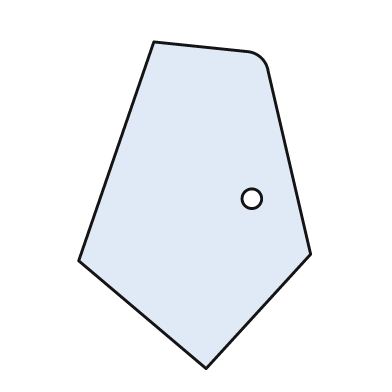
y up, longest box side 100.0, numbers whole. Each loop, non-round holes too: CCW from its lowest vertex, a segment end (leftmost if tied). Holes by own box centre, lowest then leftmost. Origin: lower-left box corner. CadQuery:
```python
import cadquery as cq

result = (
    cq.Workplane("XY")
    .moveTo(39.0, 0.0)
    .lineTo(71.0, 35.0)
    .lineTo(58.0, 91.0)
    .threePointArc((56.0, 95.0), (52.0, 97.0))
    .lineTo(23.0, 100.0)
    .lineTo(0.0, 33.0)
    .close()
    .moveTo(53.0, 52.0)
    .circle(3.0)
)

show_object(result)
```